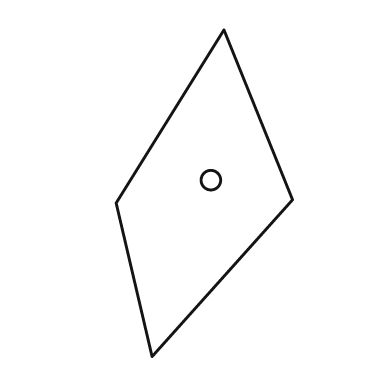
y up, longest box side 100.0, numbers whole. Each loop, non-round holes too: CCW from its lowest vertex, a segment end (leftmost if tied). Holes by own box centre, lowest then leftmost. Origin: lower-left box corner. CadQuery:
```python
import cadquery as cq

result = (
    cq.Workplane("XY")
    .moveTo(11.0, 0.0)
    .lineTo(54.0, 48.0)
    .lineTo(33.0, 100.0)
    .lineTo(0.0, 47.0)
    .close()
    .moveTo(29.0, 54.0)
    .circle(3.0)
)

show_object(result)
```